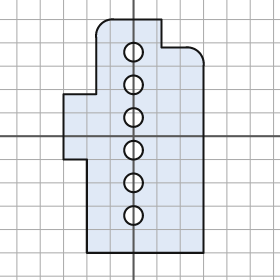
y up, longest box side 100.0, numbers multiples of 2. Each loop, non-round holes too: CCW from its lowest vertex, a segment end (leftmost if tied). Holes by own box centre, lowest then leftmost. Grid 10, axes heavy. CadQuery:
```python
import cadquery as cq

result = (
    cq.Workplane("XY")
    .moveTo(-20.0, -50.0)
    .lineTo(30.0, -50.0)
    .lineTo(30.0, 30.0)
    .threePointArc((28.0, 36.0), (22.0, 38.0))
    .lineTo(12.0, 38.0)
    .lineTo(12.0, 50.0)
    .lineTo(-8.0, 50.0)
    .threePointArc((-14.0, 48.0), (-16.0, 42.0))
    .lineTo(-16.0, 18.0)
    .lineTo(-30.0, 18.0)
    .lineTo(-30.0, -10.0)
    .lineTo(-20.0, -10.0)
    .close()
    .moveTo(0.0, -34.0)
    .circle(4.0)
    .moveTo(0.0, -20.0)
    .circle(4.0)
    .moveTo(0.0, -6.0)
    .circle(4.0)
    .moveTo(0.0, 8.0)
    .circle(4.0)
    .moveTo(0.0, 22.0)
    .circle(4.0)
    .moveTo(0.0, 36.0)
    .circle(4.0)
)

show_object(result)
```